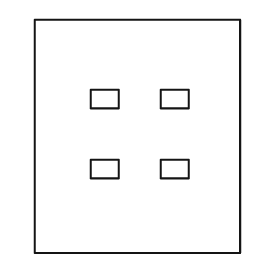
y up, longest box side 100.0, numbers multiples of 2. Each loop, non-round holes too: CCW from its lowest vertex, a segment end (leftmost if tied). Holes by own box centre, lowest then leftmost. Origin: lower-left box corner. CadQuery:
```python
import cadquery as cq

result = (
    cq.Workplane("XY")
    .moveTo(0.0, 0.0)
    .lineTo(88.0, 0.0)
    .lineTo(88.0, 100.0)
    .lineTo(0.0, 100.0)
    .close()
    .moveTo(24.0, 32.0)
    .lineTo(36.0, 32.0)
    .lineTo(36.0, 40.0)
    .lineTo(24.0, 40.0)
    .close()
    .moveTo(54.0, 32.0)
    .lineTo(66.0, 32.0)
    .lineTo(66.0, 40.0)
    .lineTo(54.0, 40.0)
    .close()
    .moveTo(24.0, 62.0)
    .lineTo(36.0, 62.0)
    .lineTo(36.0, 70.0)
    .lineTo(24.0, 70.0)
    .close()
    .moveTo(54.0, 62.0)
    .lineTo(66.0, 62.0)
    .lineTo(66.0, 70.0)
    .lineTo(54.0, 70.0)
    .close()
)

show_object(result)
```